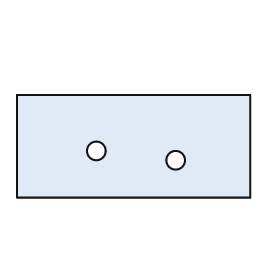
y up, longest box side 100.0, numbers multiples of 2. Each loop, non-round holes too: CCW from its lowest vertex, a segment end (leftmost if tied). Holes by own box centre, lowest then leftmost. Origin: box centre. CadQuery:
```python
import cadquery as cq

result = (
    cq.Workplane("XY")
    .moveTo(-50.0, -22.0)
    .lineTo(50.0, -22.0)
    .lineTo(50.0, 22.0)
    .lineTo(-50.0, 22.0)
    .close()
    .moveTo(18.0, -6.0)
    .circle(4.0)
    .moveTo(-16.0, -2.0)
    .circle(4.0)
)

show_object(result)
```